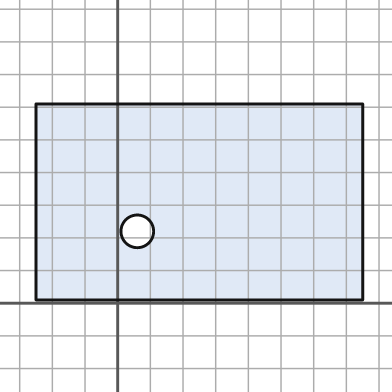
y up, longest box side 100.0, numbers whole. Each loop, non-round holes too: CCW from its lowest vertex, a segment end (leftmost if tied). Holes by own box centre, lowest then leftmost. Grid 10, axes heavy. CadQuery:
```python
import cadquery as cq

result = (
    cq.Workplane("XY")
    .moveTo(-25.0, 1.0)
    .lineTo(75.0, 1.0)
    .lineTo(75.0, 61.0)
    .lineTo(-25.0, 61.0)
    .close()
    .moveTo(6.0, 22.0)
    .circle(5.0)
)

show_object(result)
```